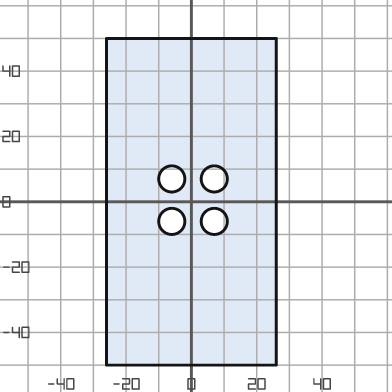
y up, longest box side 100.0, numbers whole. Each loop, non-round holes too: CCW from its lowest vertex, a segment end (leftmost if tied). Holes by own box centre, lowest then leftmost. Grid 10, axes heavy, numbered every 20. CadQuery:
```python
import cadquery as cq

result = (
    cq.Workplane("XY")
    .moveTo(-26.0, -50.0)
    .lineTo(26.0, -50.0)
    .lineTo(26.0, 50.0)
    .lineTo(-26.0, 50.0)
    .close()
    .moveTo(-6.0, -6.0)
    .circle(4.0)
    .moveTo(7.0, -6.0)
    .circle(4.0)
    .moveTo(-6.0, 7.0)
    .circle(4.0)
    .moveTo(7.0, 7.0)
    .circle(4.0)
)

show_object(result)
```